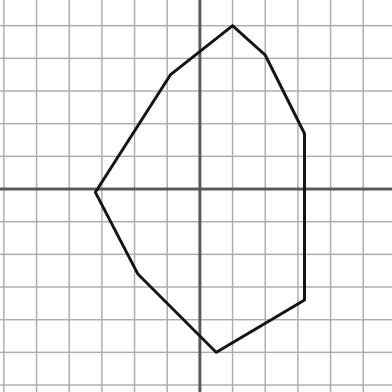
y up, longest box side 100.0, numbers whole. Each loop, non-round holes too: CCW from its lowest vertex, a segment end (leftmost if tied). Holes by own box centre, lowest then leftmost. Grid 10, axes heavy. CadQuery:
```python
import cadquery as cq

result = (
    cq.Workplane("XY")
    .moveTo(5.0, -50.0)
    .lineTo(32.0, -34.0)
    .lineTo(32.0, 17.0)
    .lineTo(20.0, 41.0)
    .lineTo(10.0, 50.0)
    .lineTo(-9.0, 35.0)
    .lineTo(-32.0, -1.0)
    .lineTo(-19.0, -26.0)
    .close()
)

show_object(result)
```